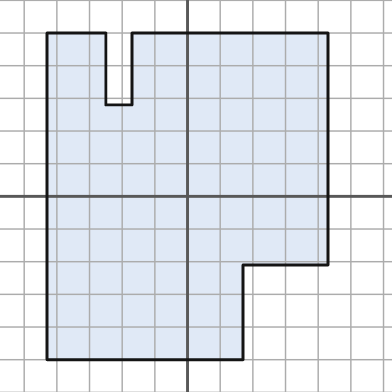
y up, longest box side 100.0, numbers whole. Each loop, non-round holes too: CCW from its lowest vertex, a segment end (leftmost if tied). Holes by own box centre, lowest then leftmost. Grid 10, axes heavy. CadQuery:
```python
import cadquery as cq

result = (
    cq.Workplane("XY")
    .moveTo(-43.0, -50.0)
    .lineTo(17.0, -50.0)
    .lineTo(17.0, -21.0)
    .lineTo(43.0, -21.0)
    .lineTo(43.0, 50.0)
    .lineTo(-17.0, 50.0)
    .lineTo(-17.0, 28.0)
    .lineTo(-25.0, 28.0)
    .lineTo(-25.0, 50.0)
    .lineTo(-43.0, 50.0)
    .close()
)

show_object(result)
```